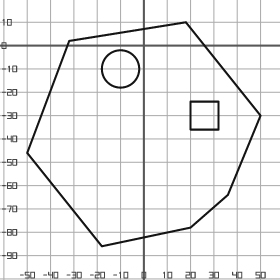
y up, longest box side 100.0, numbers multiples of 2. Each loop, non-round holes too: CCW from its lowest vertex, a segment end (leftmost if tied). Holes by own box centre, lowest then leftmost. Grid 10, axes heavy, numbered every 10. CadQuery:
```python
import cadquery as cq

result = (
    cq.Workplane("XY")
    .moveTo(-18.0, -86.0)
    .lineTo(20.0, -78.0)
    .lineTo(36.0, -64.0)
    .lineTo(50.0, -30.0)
    .lineTo(18.0, 10.0)
    .lineTo(-32.0, 2.0)
    .lineTo(-50.0, -46.0)
    .close()
    .moveTo(20.0, -36.0)
    .lineTo(32.0, -36.0)
    .lineTo(32.0, -24.0)
    .lineTo(20.0, -24.0)
    .close()
    .moveTo(-10.0, -10.0)
    .circle(8.0)
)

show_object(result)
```